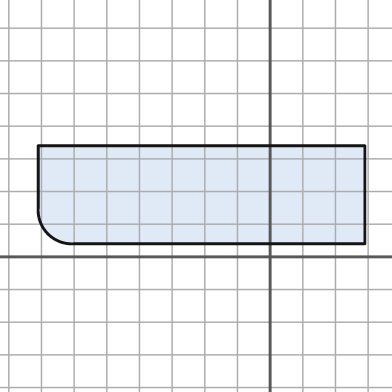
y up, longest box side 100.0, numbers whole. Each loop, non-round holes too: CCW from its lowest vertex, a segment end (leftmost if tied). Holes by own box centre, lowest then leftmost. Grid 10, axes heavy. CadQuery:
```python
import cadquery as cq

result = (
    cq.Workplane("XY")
    .moveTo(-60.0, 4.0)
    .lineTo(29.0, 4.0)
    .lineTo(29.0, 34.0)
    .lineTo(-71.0, 34.0)
    .lineTo(-71.0, 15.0)
    .threePointArc((-68.0, 7.0), (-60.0, 4.0))
    .close()
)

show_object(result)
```